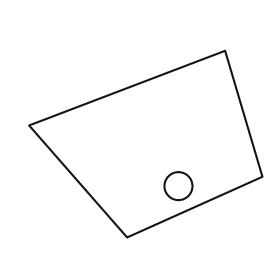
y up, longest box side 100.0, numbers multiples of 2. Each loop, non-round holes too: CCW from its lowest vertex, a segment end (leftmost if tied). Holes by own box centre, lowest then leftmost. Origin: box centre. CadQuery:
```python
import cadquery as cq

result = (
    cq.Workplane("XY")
    .moveTo(-8.0, -40.0)
    .lineTo(50.0, -14.0)
    .lineTo(34.0, 40.0)
    .lineTo(-50.0, 8.0)
    .close()
    .moveTo(14.0, -18.0)
    .circle(6.0)
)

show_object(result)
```